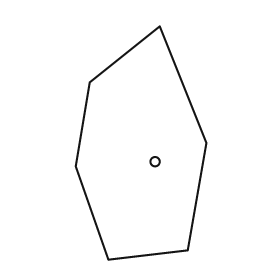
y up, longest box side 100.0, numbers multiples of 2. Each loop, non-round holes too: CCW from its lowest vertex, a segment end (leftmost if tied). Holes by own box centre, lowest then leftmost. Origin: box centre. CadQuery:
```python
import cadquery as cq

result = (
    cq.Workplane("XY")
    .moveTo(-14.0, -50.0)
    .lineTo(20.0, -46.0)
    .lineTo(28.0, 0.0)
    .lineTo(8.0, 50.0)
    .lineTo(-22.0, 26.0)
    .lineTo(-28.0, -10.0)
    .close()
    .moveTo(6.0, -8.0)
    .circle(2.0)
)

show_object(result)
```